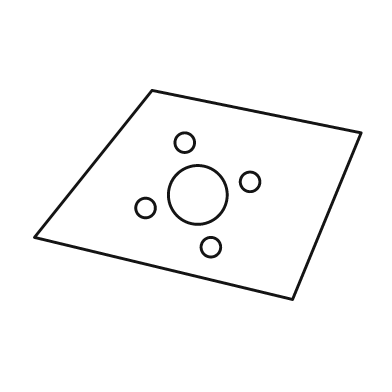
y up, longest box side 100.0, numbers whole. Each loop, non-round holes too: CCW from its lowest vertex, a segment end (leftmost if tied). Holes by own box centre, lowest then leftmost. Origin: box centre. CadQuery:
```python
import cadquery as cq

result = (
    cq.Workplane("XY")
    .moveTo(29.0, -32.0)
    .lineTo(50.0, 19.0)
    .lineTo(-14.0, 32.0)
    .lineTo(-50.0, -13.0)
    .close()
    .moveTo(4.0, -16.0)
    .circle(3.0)
    .moveTo(-16.0, -4.0)
    .circle(3.0)
    .moveTo(0.0, 0.0)
    .circle(9.0)
    .moveTo(16.0, 4.0)
    .circle(3.0)
    .moveTo(-4.0, 16.0)
    .circle(3.0)
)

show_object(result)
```